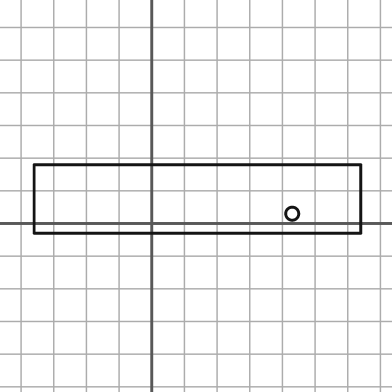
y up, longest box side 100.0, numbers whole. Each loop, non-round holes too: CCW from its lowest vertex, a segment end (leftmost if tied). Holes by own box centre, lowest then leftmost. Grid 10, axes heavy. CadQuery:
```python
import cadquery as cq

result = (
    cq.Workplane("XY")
    .moveTo(-36.0, -3.0)
    .lineTo(64.0, -3.0)
    .lineTo(64.0, 18.0)
    .lineTo(-36.0, 18.0)
    .close()
    .moveTo(43.0, 3.0)
    .circle(2.0)
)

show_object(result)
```